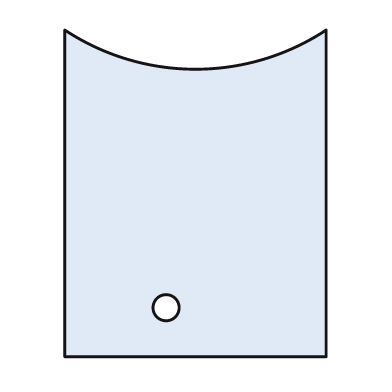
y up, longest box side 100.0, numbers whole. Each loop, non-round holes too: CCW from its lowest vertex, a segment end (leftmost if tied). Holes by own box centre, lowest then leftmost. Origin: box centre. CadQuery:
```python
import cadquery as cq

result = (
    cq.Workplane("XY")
    .moveTo(-40.0, -50.0)
    .lineTo(40.0, -50.0)
    .lineTo(40.0, 50.0)
    .threePointArc((0.0, 38.0), (-40.0, 50.0))
    .close()
    .moveTo(-9.0, -35.0)
    .circle(4.0)
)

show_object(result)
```